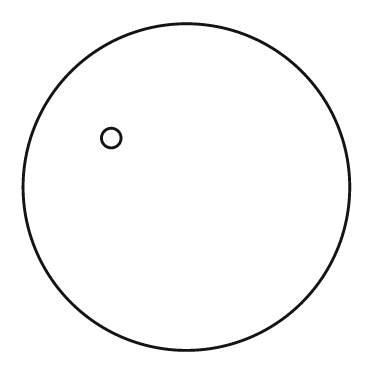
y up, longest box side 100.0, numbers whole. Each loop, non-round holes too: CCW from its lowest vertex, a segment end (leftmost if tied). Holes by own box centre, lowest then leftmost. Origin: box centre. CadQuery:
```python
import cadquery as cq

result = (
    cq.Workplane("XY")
    .moveTo(0.0, 0.0)
    .circle(50.0)
    .moveTo(-23.0, 15.0)
    .circle(3.0)
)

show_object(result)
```